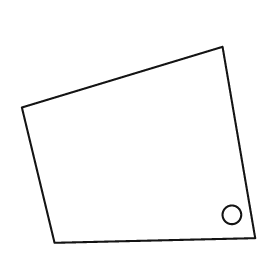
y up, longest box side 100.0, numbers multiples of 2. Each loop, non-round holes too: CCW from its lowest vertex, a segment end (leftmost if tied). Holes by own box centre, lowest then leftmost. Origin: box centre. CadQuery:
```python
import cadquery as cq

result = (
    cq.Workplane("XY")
    .moveTo(-36.0, -42.0)
    .lineTo(50.0, -40.0)
    .lineTo(36.0, 42.0)
    .lineTo(-50.0, 16.0)
    .close()
    .moveTo(40.0, -30.0)
    .circle(4.0)
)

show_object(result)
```